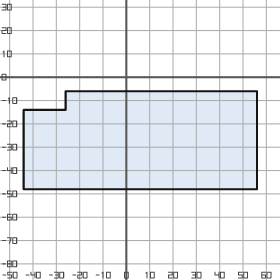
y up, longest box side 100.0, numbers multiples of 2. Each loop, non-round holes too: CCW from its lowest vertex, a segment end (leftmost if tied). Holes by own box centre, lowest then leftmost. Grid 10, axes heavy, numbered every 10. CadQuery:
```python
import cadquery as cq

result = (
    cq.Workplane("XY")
    .moveTo(-44.0, -48.0)
    .lineTo(56.0, -48.0)
    .lineTo(56.0, -6.0)
    .lineTo(-26.0, -6.0)
    .lineTo(-26.0, -14.0)
    .lineTo(-44.0, -14.0)
    .close()
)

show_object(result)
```